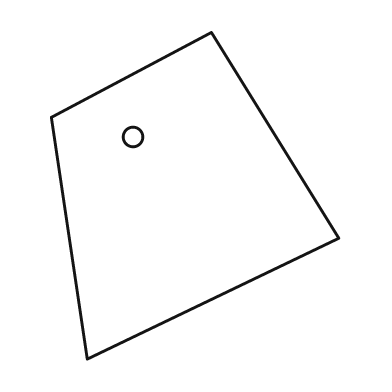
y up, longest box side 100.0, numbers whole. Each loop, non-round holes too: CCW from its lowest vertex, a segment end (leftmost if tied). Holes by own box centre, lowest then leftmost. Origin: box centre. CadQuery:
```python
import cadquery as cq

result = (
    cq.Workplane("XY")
    .moveTo(-33.0, -50.0)
    .lineTo(44.0, -13.0)
    .lineTo(5.0, 50.0)
    .lineTo(-44.0, 24.0)
    .close()
    .moveTo(-19.0, 18.0)
    .circle(3.0)
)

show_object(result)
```